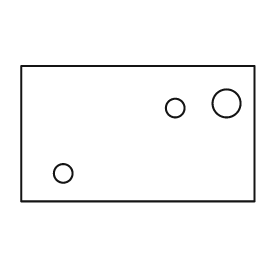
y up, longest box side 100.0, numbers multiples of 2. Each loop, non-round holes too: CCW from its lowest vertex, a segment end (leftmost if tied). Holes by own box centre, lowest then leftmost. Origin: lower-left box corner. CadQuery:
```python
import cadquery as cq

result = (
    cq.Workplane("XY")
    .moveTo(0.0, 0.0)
    .lineTo(100.0, 0.0)
    .lineTo(100.0, 58.0)
    .lineTo(0.0, 58.0)
    .close()
    .moveTo(18.0, 12.0)
    .circle(4.0)
    .moveTo(66.0, 40.0)
    .circle(4.0)
    .moveTo(88.0, 42.0)
    .circle(6.0)
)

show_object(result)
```